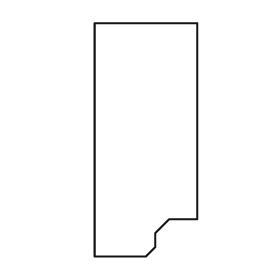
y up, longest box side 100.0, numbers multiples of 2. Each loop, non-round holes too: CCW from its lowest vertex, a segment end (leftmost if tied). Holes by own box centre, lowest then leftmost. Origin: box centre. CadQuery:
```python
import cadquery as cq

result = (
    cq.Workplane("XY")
    .moveTo(-22.0, -50.0)
    .lineTo(0.0, -50.0)
    .lineTo(4.0, -46.0)
    .lineTo(4.0, -40.0)
    .lineTo(10.0, -34.0)
    .lineTo(22.0, -34.0)
    .lineTo(22.0, 50.0)
    .lineTo(-22.0, 50.0)
    .close()
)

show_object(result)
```